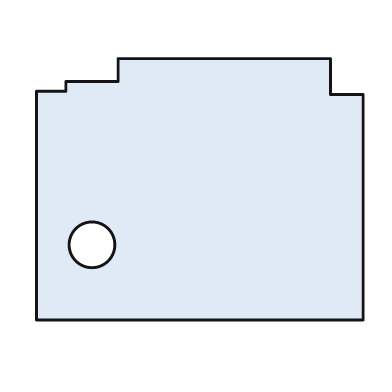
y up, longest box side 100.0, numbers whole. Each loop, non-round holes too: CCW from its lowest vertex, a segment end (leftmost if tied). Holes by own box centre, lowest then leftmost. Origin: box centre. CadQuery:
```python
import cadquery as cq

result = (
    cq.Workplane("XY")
    .moveTo(-50.0, -40.0)
    .lineTo(50.0, -40.0)
    .lineTo(50.0, 29.0)
    .lineTo(40.0, 29.0)
    .lineTo(40.0, 40.0)
    .lineTo(-25.0, 40.0)
    .lineTo(-25.0, 33.0)
    .lineTo(-41.0, 33.0)
    .lineTo(-41.0, 30.0)
    .lineTo(-50.0, 30.0)
    .close()
    .moveTo(-33.0, -17.0)
    .circle(7.0)
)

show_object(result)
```